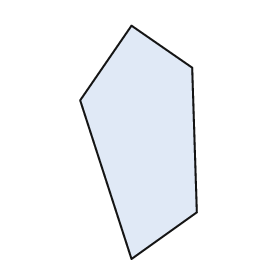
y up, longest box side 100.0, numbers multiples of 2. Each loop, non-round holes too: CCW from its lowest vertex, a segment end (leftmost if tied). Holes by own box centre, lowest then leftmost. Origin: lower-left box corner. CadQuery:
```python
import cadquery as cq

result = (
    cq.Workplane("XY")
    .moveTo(22.0, 0.0)
    .lineTo(50.0, 20.0)
    .lineTo(48.0, 82.0)
    .lineTo(22.0, 100.0)
    .lineTo(0.0, 68.0)
    .close()
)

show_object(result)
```